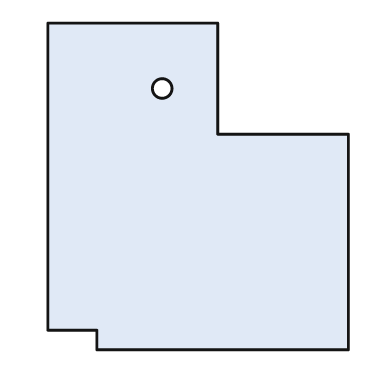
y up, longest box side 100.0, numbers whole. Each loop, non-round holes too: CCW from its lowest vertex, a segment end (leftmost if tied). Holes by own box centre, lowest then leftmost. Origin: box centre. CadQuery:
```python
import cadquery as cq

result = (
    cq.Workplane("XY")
    .moveTo(-31.0, -50.0)
    .lineTo(46.0, -50.0)
    .lineTo(46.0, 16.0)
    .lineTo(6.0, 16.0)
    .lineTo(6.0, 50.0)
    .lineTo(-46.0, 50.0)
    .lineTo(-46.0, -44.0)
    .lineTo(-31.0, -44.0)
    .close()
    .moveTo(-11.0, 30.0)
    .circle(3.0)
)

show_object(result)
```